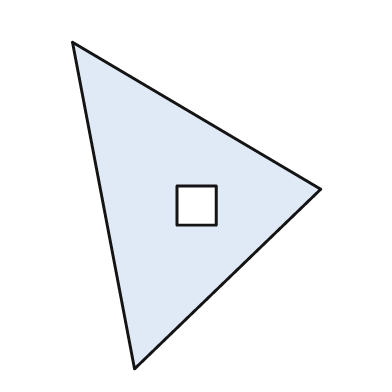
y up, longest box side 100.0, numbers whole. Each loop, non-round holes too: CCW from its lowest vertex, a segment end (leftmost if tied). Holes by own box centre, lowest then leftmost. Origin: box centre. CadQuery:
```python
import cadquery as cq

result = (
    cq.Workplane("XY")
    .moveTo(-19.0, -50.0)
    .lineTo(38.0, 5.0)
    .lineTo(-38.0, 50.0)
    .close()
    .moveTo(-6.0, -6.0)
    .lineTo(6.0, -6.0)
    .lineTo(6.0, 6.0)
    .lineTo(-6.0, 6.0)
    .close()
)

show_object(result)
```